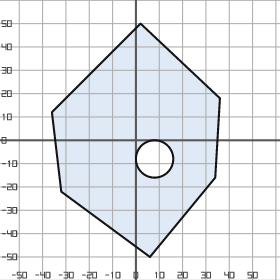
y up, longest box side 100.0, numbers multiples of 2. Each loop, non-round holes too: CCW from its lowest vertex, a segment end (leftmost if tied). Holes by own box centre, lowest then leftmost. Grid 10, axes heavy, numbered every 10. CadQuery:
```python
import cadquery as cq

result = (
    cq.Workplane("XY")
    .moveTo(6.0, -50.0)
    .lineTo(34.0, -16.0)
    .lineTo(36.0, 18.0)
    .lineTo(2.0, 50.0)
    .lineTo(-36.0, 12.0)
    .lineTo(-32.0, -22.0)
    .close()
    .moveTo(8.0, -8.0)
    .circle(8.0)
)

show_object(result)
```